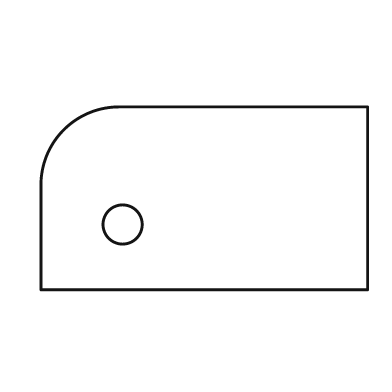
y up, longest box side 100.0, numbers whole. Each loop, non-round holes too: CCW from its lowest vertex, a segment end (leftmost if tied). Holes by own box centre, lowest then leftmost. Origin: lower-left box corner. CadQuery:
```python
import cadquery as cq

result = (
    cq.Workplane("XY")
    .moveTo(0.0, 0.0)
    .lineTo(100.0, 0.0)
    .lineTo(100.0, 56.0)
    .lineTo(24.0, 56.0)
    .threePointArc((7.0, 49.0), (0.0, 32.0))
    .close()
    .moveTo(25.0, 20.0)
    .circle(6.0)
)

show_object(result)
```